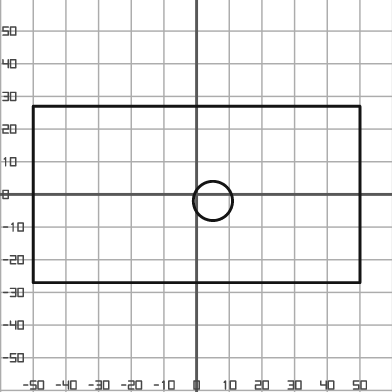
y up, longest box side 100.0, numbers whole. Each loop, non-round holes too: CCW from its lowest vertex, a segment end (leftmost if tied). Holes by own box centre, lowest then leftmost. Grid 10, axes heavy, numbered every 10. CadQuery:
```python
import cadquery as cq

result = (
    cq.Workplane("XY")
    .moveTo(-50.0, -27.0)
    .lineTo(50.0, -27.0)
    .lineTo(50.0, 27.0)
    .lineTo(-50.0, 27.0)
    .close()
    .moveTo(5.0, -2.0)
    .circle(6.0)
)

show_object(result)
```